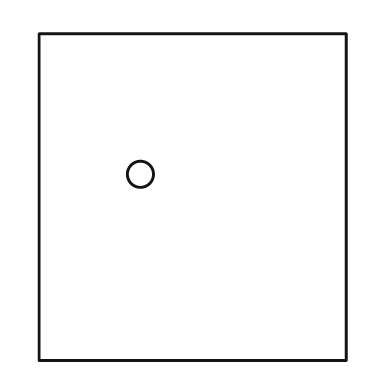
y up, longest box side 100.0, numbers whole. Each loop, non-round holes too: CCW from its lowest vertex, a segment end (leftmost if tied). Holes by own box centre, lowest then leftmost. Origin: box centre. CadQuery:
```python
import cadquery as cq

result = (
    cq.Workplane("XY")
    .moveTo(-47.0, -50.0)
    .lineTo(47.0, -50.0)
    .lineTo(47.0, 50.0)
    .lineTo(-47.0, 50.0)
    .close()
    .moveTo(-16.0, 7.0)
    .circle(4.0)
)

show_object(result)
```